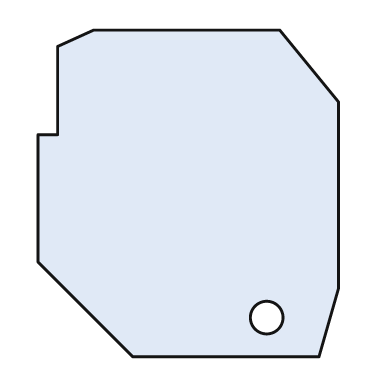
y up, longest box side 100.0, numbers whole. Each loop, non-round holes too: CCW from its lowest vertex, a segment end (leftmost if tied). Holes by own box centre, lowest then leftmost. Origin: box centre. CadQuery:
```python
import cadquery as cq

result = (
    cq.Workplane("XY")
    .moveTo(-17.0, -50.0)
    .lineTo(40.0, -50.0)
    .lineTo(46.0, -29.0)
    .lineTo(46.0, 28.0)
    .lineTo(28.0, 50.0)
    .lineTo(-29.0, 50.0)
    .lineTo(-40.0, 45.0)
    .lineTo(-40.0, 18.0)
    .lineTo(-46.0, 18.0)
    .lineTo(-46.0, -21.0)
    .close()
    .moveTo(24.0, -38.0)
    .circle(5.0)
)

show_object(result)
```